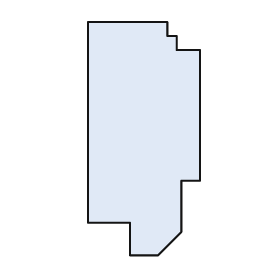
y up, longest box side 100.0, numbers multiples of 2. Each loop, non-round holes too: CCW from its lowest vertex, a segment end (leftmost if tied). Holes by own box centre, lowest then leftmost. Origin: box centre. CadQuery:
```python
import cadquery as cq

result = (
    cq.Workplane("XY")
    .moveTo(-6.0, -50.0)
    .lineTo(6.0, -50.0)
    .lineTo(16.0, -40.0)
    .lineTo(16.0, -18.0)
    .lineTo(24.0, -18.0)
    .lineTo(24.0, 38.0)
    .lineTo(14.0, 38.0)
    .lineTo(14.0, 44.0)
    .lineTo(10.0, 44.0)
    .lineTo(10.0, 50.0)
    .lineTo(-24.0, 50.0)
    .lineTo(-24.0, -36.0)
    .lineTo(-6.0, -36.0)
    .close()
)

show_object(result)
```